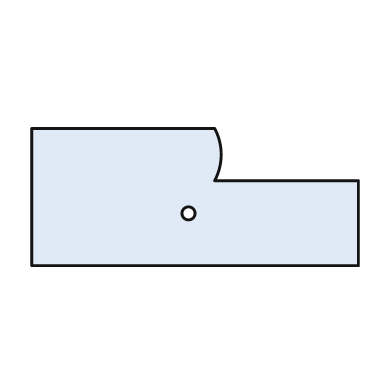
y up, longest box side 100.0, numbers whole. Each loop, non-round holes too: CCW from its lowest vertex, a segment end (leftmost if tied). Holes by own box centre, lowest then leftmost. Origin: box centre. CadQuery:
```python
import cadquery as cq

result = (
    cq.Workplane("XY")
    .moveTo(-50.0, -21.0)
    .lineTo(50.0, -21.0)
    .lineTo(50.0, 5.0)
    .lineTo(6.0, 5.0)
    .threePointArc((8.0, 13.0), (6.0, 21.0))
    .lineTo(-50.0, 21.0)
    .close()
    .moveTo(-2.0, -5.0)
    .circle(2.0)
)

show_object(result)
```